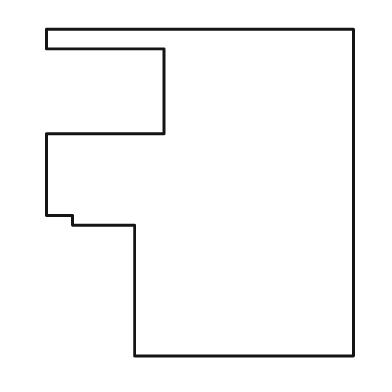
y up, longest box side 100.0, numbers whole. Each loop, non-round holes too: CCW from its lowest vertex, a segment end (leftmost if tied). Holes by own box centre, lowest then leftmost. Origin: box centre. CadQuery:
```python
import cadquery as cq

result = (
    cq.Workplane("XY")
    .moveTo(-20.0, -50.0)
    .lineTo(47.0, -50.0)
    .lineTo(47.0, 50.0)
    .lineTo(-47.0, 50.0)
    .lineTo(-47.0, 44.0)
    .lineTo(-11.0, 44.0)
    .lineTo(-11.0, 18.0)
    .lineTo(-47.0, 18.0)
    .lineTo(-47.0, -7.0)
    .lineTo(-39.0, -7.0)
    .lineTo(-39.0, -10.0)
    .lineTo(-20.0, -10.0)
    .close()
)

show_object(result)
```